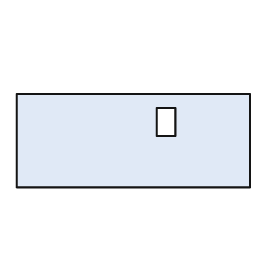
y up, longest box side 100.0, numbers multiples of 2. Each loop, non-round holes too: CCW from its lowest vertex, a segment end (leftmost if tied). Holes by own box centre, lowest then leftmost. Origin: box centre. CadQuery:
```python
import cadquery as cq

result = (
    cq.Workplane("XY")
    .moveTo(-50.0, -20.0)
    .lineTo(50.0, -20.0)
    .lineTo(50.0, 20.0)
    .lineTo(-50.0, 20.0)
    .close()
    .moveTo(10.0, 2.0)
    .lineTo(18.0, 2.0)
    .lineTo(18.0, 14.0)
    .lineTo(10.0, 14.0)
    .close()
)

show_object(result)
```